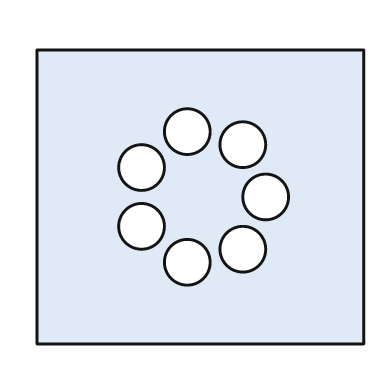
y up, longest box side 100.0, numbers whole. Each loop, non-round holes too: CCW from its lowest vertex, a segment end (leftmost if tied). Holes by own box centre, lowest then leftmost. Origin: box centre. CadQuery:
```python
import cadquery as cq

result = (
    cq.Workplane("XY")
    .moveTo(-50.0, -45.0)
    .lineTo(50.0, -45.0)
    .lineTo(50.0, 45.0)
    .lineTo(-50.0, 45.0)
    .close()
    .moveTo(-4.0, -20.0)
    .circle(7.0)
    .moveTo(13.0, -16.0)
    .circle(7.0)
    .moveTo(-18.0, -9.0)
    .circle(7.0)
    .moveTo(20.0, 0.0)
    .circle(7.0)
    .moveTo(-18.0, 9.0)
    .circle(7.0)
    .moveTo(13.0, 16.0)
    .circle(7.0)
    .moveTo(-4.0, 20.0)
    .circle(7.0)
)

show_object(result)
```